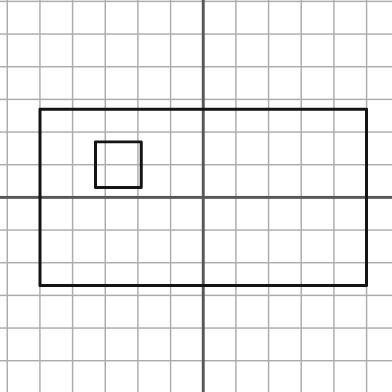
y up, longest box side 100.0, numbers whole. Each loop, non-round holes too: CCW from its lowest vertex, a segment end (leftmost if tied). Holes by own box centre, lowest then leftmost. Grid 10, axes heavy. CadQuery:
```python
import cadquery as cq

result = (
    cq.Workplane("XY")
    .moveTo(-50.0, -27.0)
    .lineTo(50.0, -27.0)
    .lineTo(50.0, 27.0)
    .lineTo(-50.0, 27.0)
    .close()
    .moveTo(-33.0, 3.0)
    .lineTo(-19.0, 3.0)
    .lineTo(-19.0, 17.0)
    .lineTo(-33.0, 17.0)
    .close()
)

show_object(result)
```